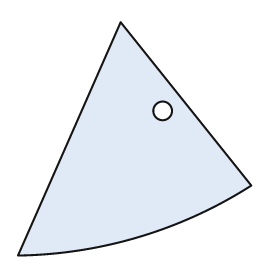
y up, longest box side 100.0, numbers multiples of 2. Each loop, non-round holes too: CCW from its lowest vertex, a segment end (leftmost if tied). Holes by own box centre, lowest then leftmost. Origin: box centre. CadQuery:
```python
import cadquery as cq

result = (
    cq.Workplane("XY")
    .moveTo(-50.0, -50.0)
    .threePointArc((2.0, -42.0), (50.0, -20.0))
    .lineTo(-6.0, 50.0)
    .close()
    .moveTo(12.0, 12.0)
    .circle(4.0)
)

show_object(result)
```